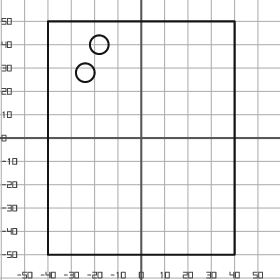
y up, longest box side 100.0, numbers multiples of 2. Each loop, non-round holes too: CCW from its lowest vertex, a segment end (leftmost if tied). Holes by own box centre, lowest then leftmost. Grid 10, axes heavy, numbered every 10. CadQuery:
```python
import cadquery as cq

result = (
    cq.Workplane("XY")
    .moveTo(-40.0, -50.0)
    .lineTo(40.0, -50.0)
    .lineTo(40.0, 50.0)
    .lineTo(-40.0, 50.0)
    .close()
    .moveTo(-24.0, 28.0)
    .circle(4.0)
    .moveTo(-18.0, 40.0)
    .circle(4.0)
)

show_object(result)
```